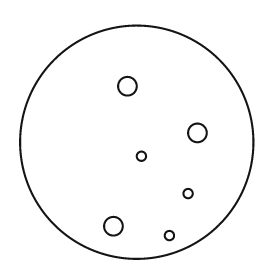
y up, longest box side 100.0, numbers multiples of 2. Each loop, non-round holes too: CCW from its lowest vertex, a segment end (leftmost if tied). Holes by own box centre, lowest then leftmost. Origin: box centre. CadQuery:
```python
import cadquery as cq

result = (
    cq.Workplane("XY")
    .moveTo(0.0, 0.0)
    .circle(50.0)
    .moveTo(14.0, -40.0)
    .circle(2.0)
    .moveTo(-10.0, -36.0)
    .circle(4.0)
    .moveTo(22.0, -22.0)
    .circle(2.0)
    .moveTo(2.0, -6.0)
    .circle(2.0)
    .moveTo(26.0, 4.0)
    .circle(4.0)
    .moveTo(-4.0, 24.0)
    .circle(4.0)
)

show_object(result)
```